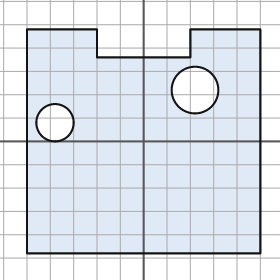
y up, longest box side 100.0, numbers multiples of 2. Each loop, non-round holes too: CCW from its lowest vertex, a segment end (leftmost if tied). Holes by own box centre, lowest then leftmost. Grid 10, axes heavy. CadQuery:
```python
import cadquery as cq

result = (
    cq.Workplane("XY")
    .moveTo(-50.0, -48.0)
    .lineTo(50.0, -48.0)
    .lineTo(50.0, 48.0)
    .lineTo(20.0, 48.0)
    .lineTo(20.0, 36.0)
    .lineTo(-20.0, 36.0)
    .lineTo(-20.0, 48.0)
    .lineTo(-50.0, 48.0)
    .close()
    .moveTo(-38.0, 8.0)
    .circle(8.0)
    .moveTo(22.0, 22.0)
    .circle(10.0)
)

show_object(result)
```